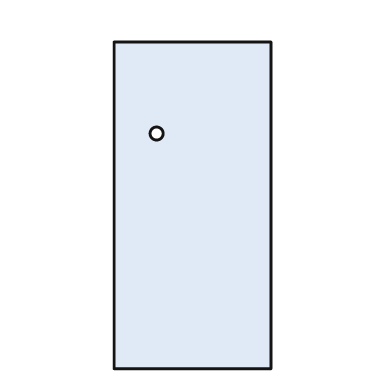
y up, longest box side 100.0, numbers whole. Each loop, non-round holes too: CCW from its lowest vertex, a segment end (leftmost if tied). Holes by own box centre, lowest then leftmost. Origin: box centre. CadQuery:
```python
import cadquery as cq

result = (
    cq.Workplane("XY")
    .moveTo(-24.0, -50.0)
    .lineTo(24.0, -50.0)
    .lineTo(24.0, 50.0)
    .lineTo(-24.0, 50.0)
    .close()
    .moveTo(-11.0, 22.0)
    .circle(2.0)
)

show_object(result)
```